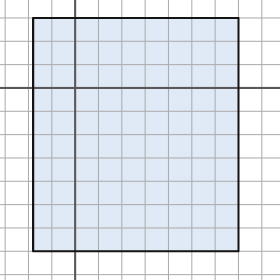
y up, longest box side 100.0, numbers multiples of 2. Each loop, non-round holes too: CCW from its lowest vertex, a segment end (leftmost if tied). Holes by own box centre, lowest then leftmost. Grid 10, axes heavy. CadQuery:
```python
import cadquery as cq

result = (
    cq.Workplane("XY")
    .moveTo(-18.0, -70.0)
    .lineTo(70.0, -70.0)
    .lineTo(70.0, 30.0)
    .lineTo(-18.0, 30.0)
    .close()
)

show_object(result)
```